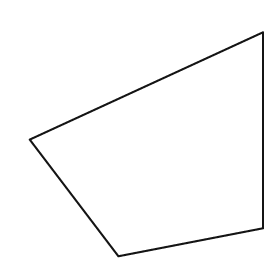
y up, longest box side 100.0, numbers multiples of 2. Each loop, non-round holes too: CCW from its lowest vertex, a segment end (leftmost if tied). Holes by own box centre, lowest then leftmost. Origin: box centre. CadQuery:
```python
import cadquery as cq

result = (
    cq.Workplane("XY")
    .moveTo(-12.0, -48.0)
    .lineTo(50.0, -36.0)
    .lineTo(50.0, 48.0)
    .lineTo(-50.0, 2.0)
    .close()
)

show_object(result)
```